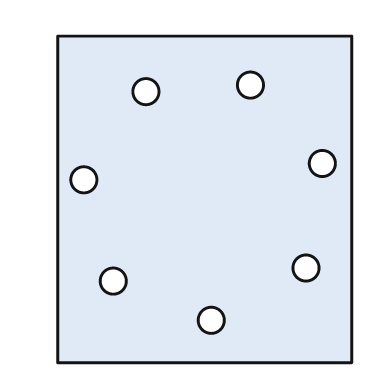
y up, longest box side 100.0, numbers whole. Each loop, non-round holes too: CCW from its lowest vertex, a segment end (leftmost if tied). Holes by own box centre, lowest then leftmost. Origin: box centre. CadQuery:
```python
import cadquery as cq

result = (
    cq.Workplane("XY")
    .moveTo(-45.0, -50.0)
    .lineTo(45.0, -50.0)
    .lineTo(45.0, 50.0)
    .lineTo(-45.0, 50.0)
    .close()
    .moveTo(2.0, -37.0)
    .circle(4.0)
    .moveTo(-28.0, -25.0)
    .circle(4.0)
    .moveTo(31.0, -21.0)
    .circle(4.0)
    .moveTo(-37.0, 6.0)
    .circle(4.0)
    .moveTo(36.0, 11.0)
    .circle(4.0)
    .moveTo(-18.0, 33.0)
    .circle(4.0)
    .moveTo(14.0, 35.0)
    .circle(4.0)
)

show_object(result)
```